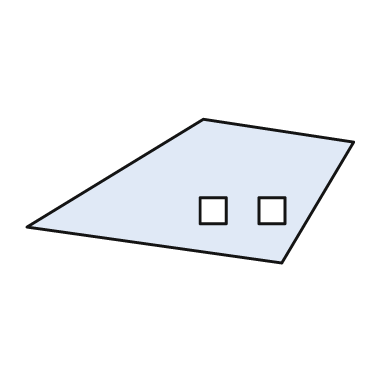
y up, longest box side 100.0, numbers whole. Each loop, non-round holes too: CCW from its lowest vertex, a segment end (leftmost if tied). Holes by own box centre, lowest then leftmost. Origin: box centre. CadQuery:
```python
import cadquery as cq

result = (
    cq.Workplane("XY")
    .moveTo(28.0, -22.0)
    .lineTo(50.0, 15.0)
    .lineTo(4.0, 22.0)
    .lineTo(-50.0, -11.0)
    .close()
    .moveTo(3.0, -10.0)
    .lineTo(11.0, -10.0)
    .lineTo(11.0, -2.0)
    .lineTo(3.0, -2.0)
    .close()
    .moveTo(21.0, -10.0)
    .lineTo(29.0, -10.0)
    .lineTo(29.0, -2.0)
    .lineTo(21.0, -2.0)
    .close()
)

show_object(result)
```